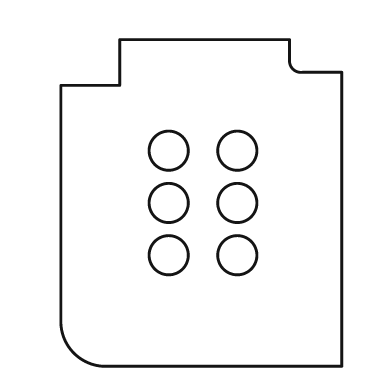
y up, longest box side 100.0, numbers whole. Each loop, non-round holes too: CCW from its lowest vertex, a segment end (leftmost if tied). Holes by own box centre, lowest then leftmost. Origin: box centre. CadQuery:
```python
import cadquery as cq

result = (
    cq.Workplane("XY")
    .moveTo(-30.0, -50.0)
    .lineTo(43.0, -50.0)
    .lineTo(43.0, 40.0)
    .lineTo(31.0, 40.0)
    .threePointArc((28.0, 41.0), (27.0, 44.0))
    .lineTo(27.0, 50.0)
    .lineTo(-25.0, 50.0)
    .lineTo(-25.0, 36.0)
    .lineTo(-43.0, 36.0)
    .lineTo(-43.0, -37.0)
    .threePointArc((-39.0, -46.0), (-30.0, -50.0))
    .close()
    .moveTo(-10.0, -16.0)
    .circle(6.0)
    .moveTo(11.0, -16.0)
    .circle(6.0)
    .moveTo(-10.0, 0.0)
    .circle(6.0)
    .moveTo(11.0, 0.0)
    .circle(6.0)
    .moveTo(-10.0, 16.0)
    .circle(6.0)
    .moveTo(11.0, 16.0)
    .circle(6.0)
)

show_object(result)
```